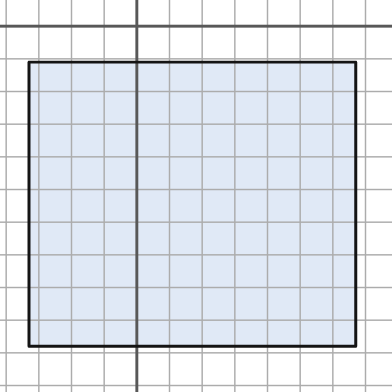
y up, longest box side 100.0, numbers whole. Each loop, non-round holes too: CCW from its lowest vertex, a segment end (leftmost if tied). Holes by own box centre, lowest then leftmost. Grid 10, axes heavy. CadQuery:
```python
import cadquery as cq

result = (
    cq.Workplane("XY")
    .moveTo(-33.0, -98.0)
    .lineTo(67.0, -98.0)
    .lineTo(67.0, -11.0)
    .lineTo(-33.0, -11.0)
    .close()
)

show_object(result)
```